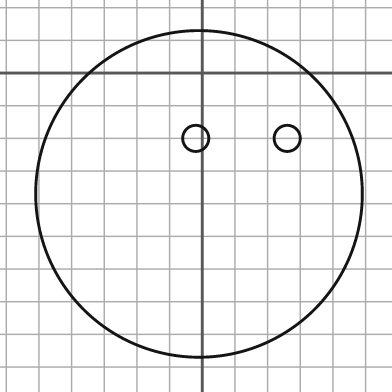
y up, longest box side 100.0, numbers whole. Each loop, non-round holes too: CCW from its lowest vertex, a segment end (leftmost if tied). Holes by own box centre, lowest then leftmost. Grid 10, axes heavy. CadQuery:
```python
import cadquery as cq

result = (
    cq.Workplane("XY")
    .moveTo(-1.0, -37.0)
    .circle(50.0)
    .moveTo(-2.0, -20.0)
    .circle(4.0)
    .moveTo(26.0, -20.0)
    .circle(4.0)
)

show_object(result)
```